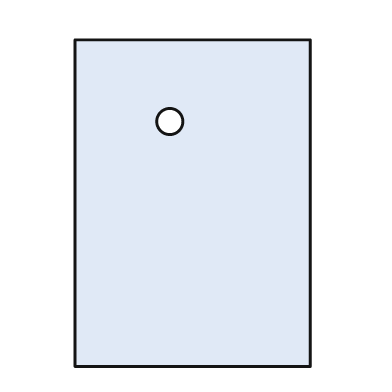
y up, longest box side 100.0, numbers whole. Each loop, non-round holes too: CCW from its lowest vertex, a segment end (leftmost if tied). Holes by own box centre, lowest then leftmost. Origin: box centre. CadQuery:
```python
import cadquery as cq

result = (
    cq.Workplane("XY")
    .moveTo(-36.0, -50.0)
    .lineTo(36.0, -50.0)
    .lineTo(36.0, 50.0)
    .lineTo(-36.0, 50.0)
    .close()
    .moveTo(-7.0, 25.0)
    .circle(4.0)
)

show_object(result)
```